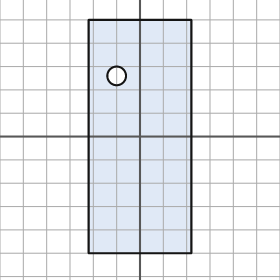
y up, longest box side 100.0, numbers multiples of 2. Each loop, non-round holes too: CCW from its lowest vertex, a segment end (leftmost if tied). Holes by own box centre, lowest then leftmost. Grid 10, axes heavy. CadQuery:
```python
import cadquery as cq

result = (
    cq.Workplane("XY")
    .moveTo(-22.0, -50.0)
    .lineTo(22.0, -50.0)
    .lineTo(22.0, 50.0)
    .lineTo(-22.0, 50.0)
    .close()
    .moveTo(-10.0, 26.0)
    .circle(4.0)
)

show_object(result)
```